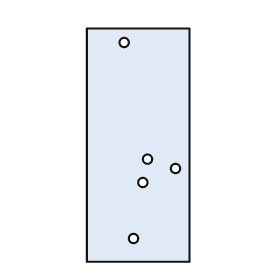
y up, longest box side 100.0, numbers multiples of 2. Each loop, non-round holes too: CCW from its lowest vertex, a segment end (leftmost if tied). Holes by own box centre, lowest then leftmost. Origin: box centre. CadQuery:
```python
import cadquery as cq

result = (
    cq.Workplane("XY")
    .moveTo(-22.0, -50.0)
    .lineTo(22.0, -50.0)
    .lineTo(22.0, 50.0)
    .lineTo(-22.0, 50.0)
    .close()
    .moveTo(-2.0, -40.0)
    .circle(2.0)
    .moveTo(2.0, -16.0)
    .circle(2.0)
    .moveTo(16.0, -10.0)
    .circle(2.0)
    .moveTo(4.0, -6.0)
    .circle(2.0)
    .moveTo(-6.0, 44.0)
    .circle(2.0)
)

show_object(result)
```